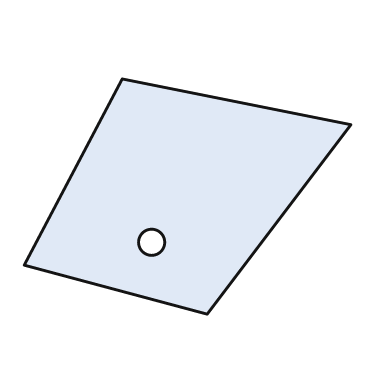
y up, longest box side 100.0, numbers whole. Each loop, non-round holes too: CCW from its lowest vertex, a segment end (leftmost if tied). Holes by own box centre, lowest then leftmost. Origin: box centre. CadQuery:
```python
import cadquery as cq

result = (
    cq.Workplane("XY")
    .moveTo(6.0, -36.0)
    .lineTo(50.0, 22.0)
    .lineTo(-20.0, 36.0)
    .lineTo(-50.0, -21.0)
    .close()
    .moveTo(-11.0, -14.0)
    .circle(4.0)
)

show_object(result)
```